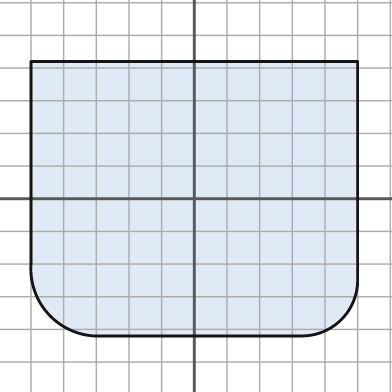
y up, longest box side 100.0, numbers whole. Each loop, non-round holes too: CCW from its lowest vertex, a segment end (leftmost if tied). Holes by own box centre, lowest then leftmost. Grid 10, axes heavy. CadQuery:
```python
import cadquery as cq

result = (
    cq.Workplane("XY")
    .moveTo(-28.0, -42.0)
    .lineTo(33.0, -42.0)
    .threePointArc((45.0, -37.0), (50.0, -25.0))
    .lineTo(50.0, 42.0)
    .lineTo(-50.0, 42.0)
    .lineTo(-50.0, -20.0)
    .threePointArc((-44.0, -36.0), (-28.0, -42.0))
    .close()
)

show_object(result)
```